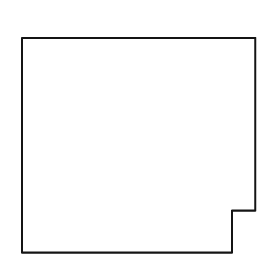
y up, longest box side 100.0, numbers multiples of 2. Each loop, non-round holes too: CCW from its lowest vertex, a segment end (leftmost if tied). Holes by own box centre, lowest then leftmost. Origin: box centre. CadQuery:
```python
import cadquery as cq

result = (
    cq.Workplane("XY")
    .moveTo(-50.0, -46.0)
    .lineTo(40.0, -46.0)
    .lineTo(40.0, -28.0)
    .lineTo(50.0, -28.0)
    .lineTo(50.0, 46.0)
    .lineTo(-50.0, 46.0)
    .close()
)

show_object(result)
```